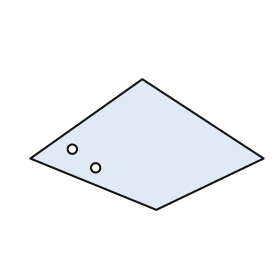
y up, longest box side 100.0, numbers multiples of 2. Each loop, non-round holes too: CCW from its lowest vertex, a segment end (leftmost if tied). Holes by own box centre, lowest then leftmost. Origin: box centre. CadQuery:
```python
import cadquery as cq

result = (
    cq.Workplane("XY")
    .moveTo(4.0, -28.0)
    .lineTo(50.0, -6.0)
    .lineTo(-2.0, 28.0)
    .lineTo(-50.0, -6.0)
    .close()
    .moveTo(-22.0, -10.0)
    .circle(2.0)
    .moveTo(-32.0, -2.0)
    .circle(2.0)
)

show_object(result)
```